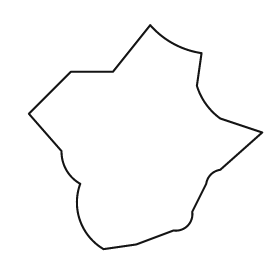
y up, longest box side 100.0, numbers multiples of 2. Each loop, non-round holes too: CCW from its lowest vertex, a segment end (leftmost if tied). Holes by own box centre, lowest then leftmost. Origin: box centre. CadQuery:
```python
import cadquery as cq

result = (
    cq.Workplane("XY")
    .moveTo(-18.0, -48.0)
    .lineTo(-4.0, -46.0)
    .lineTo(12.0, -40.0)
    .threePointArc((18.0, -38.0), (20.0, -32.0))
    .lineTo(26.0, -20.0)
    .threePointArc((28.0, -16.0), (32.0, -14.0))
    .lineTo(50.0, 2.0)
    .lineTo(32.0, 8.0)
    .threePointArc((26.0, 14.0), (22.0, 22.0))
    .lineTo(24.0, 36.0)
    .threePointArc((12.0, 40.0), (2.0, 48.0))
    .lineTo(-14.0, 28.0)
    .lineTo(-32.0, 28.0)
    .lineTo(-50.0, 10.0)
    .lineTo(-36.0, -6.0)
    .threePointArc((-34.0, -14.0), (-28.0, -20.0))
    .threePointArc((-28.0, -36.0), (-18.0, -48.0))
    .close()
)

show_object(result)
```